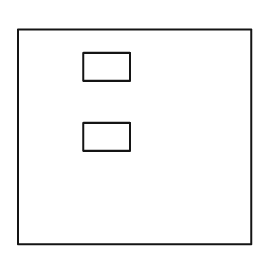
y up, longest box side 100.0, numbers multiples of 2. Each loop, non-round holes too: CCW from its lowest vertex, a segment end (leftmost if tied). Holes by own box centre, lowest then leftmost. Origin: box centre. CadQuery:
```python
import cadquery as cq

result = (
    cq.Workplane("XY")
    .moveTo(-50.0, -46.0)
    .lineTo(50.0, -46.0)
    .lineTo(50.0, 46.0)
    .lineTo(-50.0, 46.0)
    .close()
    .moveTo(-22.0, -6.0)
    .lineTo(-2.0, -6.0)
    .lineTo(-2.0, 6.0)
    .lineTo(-22.0, 6.0)
    .close()
    .moveTo(-22.0, 24.0)
    .lineTo(-2.0, 24.0)
    .lineTo(-2.0, 36.0)
    .lineTo(-22.0, 36.0)
    .close()
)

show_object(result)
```